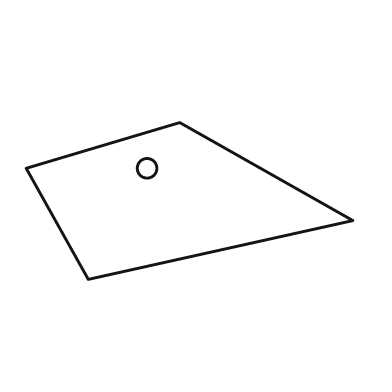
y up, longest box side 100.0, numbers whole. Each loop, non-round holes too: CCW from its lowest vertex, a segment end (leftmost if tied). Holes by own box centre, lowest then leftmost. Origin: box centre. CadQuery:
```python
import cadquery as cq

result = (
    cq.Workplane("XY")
    .moveTo(-31.0, -24.0)
    .lineTo(50.0, -6.0)
    .lineTo(-3.0, 24.0)
    .lineTo(-50.0, 10.0)
    .close()
    .moveTo(-13.0, 10.0)
    .circle(3.0)
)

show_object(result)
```